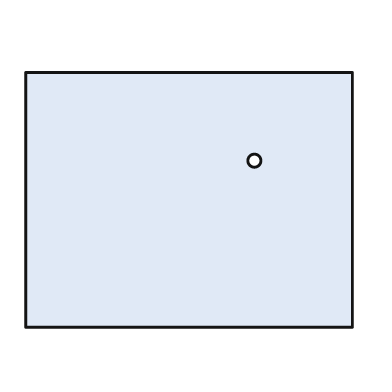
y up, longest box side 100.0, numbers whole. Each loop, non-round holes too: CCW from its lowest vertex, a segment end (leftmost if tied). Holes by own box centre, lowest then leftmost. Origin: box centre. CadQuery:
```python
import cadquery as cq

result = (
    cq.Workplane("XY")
    .moveTo(-50.0, -39.0)
    .lineTo(50.0, -39.0)
    .lineTo(50.0, 39.0)
    .lineTo(-50.0, 39.0)
    .close()
    .moveTo(20.0, 12.0)
    .circle(2.0)
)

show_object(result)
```